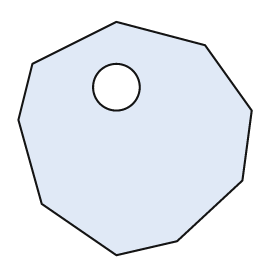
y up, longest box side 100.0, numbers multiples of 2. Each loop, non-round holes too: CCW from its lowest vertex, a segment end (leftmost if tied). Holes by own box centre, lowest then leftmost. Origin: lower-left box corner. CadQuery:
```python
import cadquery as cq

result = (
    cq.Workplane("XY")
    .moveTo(42.0, 0.0)
    .lineTo(68.0, 6.0)
    .lineTo(96.0, 32.0)
    .lineTo(100.0, 62.0)
    .lineTo(80.0, 90.0)
    .lineTo(42.0, 100.0)
    .lineTo(6.0, 82.0)
    .lineTo(0.0, 58.0)
    .lineTo(10.0, 22.0)
    .close()
    .moveTo(42.0, 72.0)
    .circle(10.0)
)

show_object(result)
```